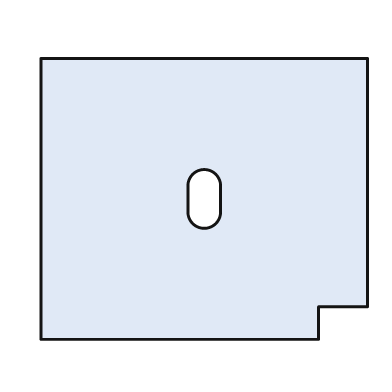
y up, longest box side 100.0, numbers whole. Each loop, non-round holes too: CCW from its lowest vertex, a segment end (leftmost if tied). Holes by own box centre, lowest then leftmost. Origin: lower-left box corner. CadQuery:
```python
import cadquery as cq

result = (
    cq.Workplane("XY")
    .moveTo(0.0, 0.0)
    .lineTo(85.0, 0.0)
    .lineTo(85.0, 10.0)
    .lineTo(100.0, 10.0)
    .lineTo(100.0, 86.0)
    .lineTo(0.0, 86.0)
    .close()
    .moveTo(45.0, 39.0)
    .threePointArc((50.0, 34.0), (55.0, 39.0))
    .lineTo(55.0, 47.0)
    .threePointArc((50.0, 52.0), (45.0, 47.0))
    .close()
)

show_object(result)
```